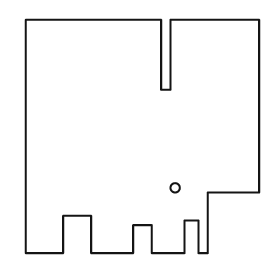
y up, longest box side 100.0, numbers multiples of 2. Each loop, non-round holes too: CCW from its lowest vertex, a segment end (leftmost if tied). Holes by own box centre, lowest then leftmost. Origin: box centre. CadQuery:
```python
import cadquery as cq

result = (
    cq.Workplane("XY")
    .moveTo(-50.0, -50.0)
    .lineTo(-34.0, -50.0)
    .lineTo(-34.0, -34.0)
    .lineTo(-22.0, -34.0)
    .lineTo(-22.0, -50.0)
    .lineTo(-4.0, -50.0)
    .lineTo(-4.0, -38.0)
    .lineTo(4.0, -38.0)
    .lineTo(4.0, -50.0)
    .lineTo(18.0, -50.0)
    .lineTo(18.0, -36.0)
    .lineTo(24.0, -36.0)
    .lineTo(24.0, -50.0)
    .lineTo(28.0, -50.0)
    .lineTo(28.0, -24.0)
    .lineTo(50.0, -24.0)
    .lineTo(50.0, 50.0)
    .lineTo(12.0, 50.0)
    .lineTo(12.0, 20.0)
    .lineTo(8.0, 20.0)
    .lineTo(8.0, 50.0)
    .lineTo(-50.0, 50.0)
    .close()
    .moveTo(14.0, -22.0)
    .circle(2.0)
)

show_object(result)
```